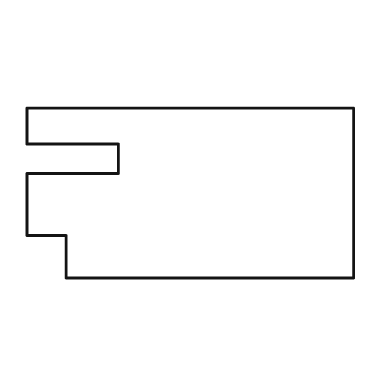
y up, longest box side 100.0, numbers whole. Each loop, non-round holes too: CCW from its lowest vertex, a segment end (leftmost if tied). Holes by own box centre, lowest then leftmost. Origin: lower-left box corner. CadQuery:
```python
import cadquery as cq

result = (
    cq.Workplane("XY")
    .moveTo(12.0, 0.0)
    .lineTo(100.0, 0.0)
    .lineTo(100.0, 52.0)
    .lineTo(0.0, 52.0)
    .lineTo(0.0, 41.0)
    .lineTo(28.0, 41.0)
    .lineTo(28.0, 32.0)
    .lineTo(0.0, 32.0)
    .lineTo(0.0, 13.0)
    .lineTo(12.0, 13.0)
    .close()
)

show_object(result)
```